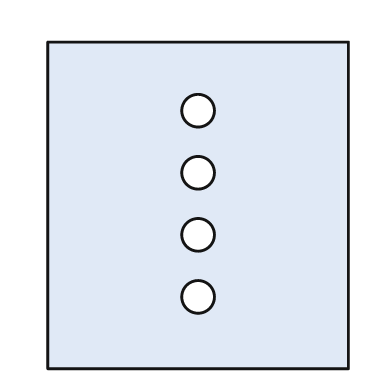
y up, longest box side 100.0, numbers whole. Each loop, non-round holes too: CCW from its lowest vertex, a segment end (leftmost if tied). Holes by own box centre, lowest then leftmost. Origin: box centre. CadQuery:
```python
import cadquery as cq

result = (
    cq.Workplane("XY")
    .moveTo(-46.0, -50.0)
    .lineTo(46.0, -50.0)
    .lineTo(46.0, 50.0)
    .lineTo(-46.0, 50.0)
    .close()
    .moveTo(0.0, -28.0)
    .circle(5.0)
    .moveTo(0.0, -9.0)
    .circle(5.0)
    .moveTo(0.0, 10.0)
    .circle(5.0)
    .moveTo(0.0, 29.0)
    .circle(5.0)
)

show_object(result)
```